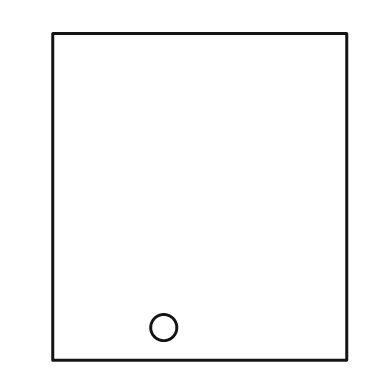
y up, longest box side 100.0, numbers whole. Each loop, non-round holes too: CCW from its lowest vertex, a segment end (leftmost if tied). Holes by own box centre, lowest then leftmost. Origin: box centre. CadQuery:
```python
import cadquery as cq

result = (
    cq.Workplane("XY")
    .moveTo(-45.0, -50.0)
    .lineTo(45.0, -50.0)
    .lineTo(45.0, 50.0)
    .lineTo(-45.0, 50.0)
    .close()
    .moveTo(-11.0, -40.0)
    .circle(4.0)
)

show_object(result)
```